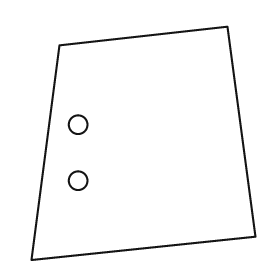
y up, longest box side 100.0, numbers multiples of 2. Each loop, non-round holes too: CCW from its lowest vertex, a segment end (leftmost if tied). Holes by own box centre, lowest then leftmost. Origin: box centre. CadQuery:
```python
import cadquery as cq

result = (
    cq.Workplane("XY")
    .moveTo(-48.0, -50.0)
    .lineTo(48.0, -40.0)
    .lineTo(36.0, 50.0)
    .lineTo(-36.0, 42.0)
    .close()
    .moveTo(-28.0, -16.0)
    .circle(4.0)
    .moveTo(-28.0, 8.0)
    .circle(4.0)
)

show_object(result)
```